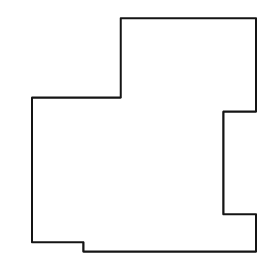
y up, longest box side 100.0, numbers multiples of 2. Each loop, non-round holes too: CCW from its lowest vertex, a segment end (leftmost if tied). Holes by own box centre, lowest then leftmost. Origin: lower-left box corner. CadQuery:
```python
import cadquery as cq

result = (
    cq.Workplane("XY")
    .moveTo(22.0, 0.0)
    .lineTo(96.0, 0.0)
    .lineTo(96.0, 16.0)
    .lineTo(82.0, 16.0)
    .lineTo(82.0, 60.0)
    .lineTo(96.0, 60.0)
    .lineTo(96.0, 100.0)
    .lineTo(38.0, 100.0)
    .lineTo(38.0, 66.0)
    .lineTo(0.0, 66.0)
    .lineTo(0.0, 4.0)
    .lineTo(22.0, 4.0)
    .close()
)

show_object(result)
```